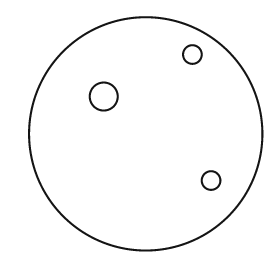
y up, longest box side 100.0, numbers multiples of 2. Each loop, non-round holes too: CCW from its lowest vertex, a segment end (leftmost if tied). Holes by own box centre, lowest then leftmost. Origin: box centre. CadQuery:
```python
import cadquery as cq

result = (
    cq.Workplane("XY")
    .moveTo(0.0, 0.0)
    .circle(50.0)
    .moveTo(28.0, -20.0)
    .circle(4.0)
    .moveTo(-18.0, 16.0)
    .circle(6.0)
    .moveTo(20.0, 34.0)
    .circle(4.0)
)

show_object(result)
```